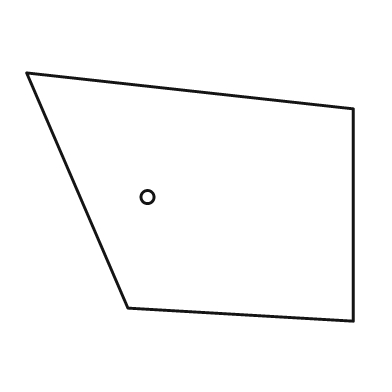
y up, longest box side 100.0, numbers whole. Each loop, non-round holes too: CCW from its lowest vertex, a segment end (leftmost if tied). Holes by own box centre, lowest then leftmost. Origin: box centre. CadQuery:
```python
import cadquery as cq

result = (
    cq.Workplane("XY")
    .moveTo(50.0, -38.0)
    .lineTo(50.0, 27.0)
    .lineTo(-50.0, 38.0)
    .lineTo(-19.0, -34.0)
    .close()
    .moveTo(-13.0, 0.0)
    .circle(2.0)
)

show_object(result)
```